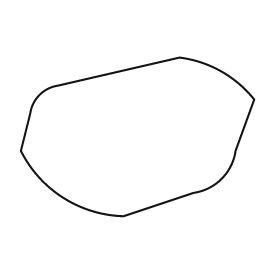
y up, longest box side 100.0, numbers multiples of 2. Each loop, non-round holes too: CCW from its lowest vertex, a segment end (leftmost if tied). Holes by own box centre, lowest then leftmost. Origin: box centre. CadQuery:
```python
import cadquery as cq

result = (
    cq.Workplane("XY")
    .moveTo(-6.0, -34.0)
    .lineTo(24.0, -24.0)
    .threePointArc((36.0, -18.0), (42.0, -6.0))
    .lineTo(50.0, 16.0)
    .threePointArc((36.0, 28.0), (18.0, 34.0))
    .lineTo(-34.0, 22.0)
    .threePointArc((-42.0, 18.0), (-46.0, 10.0))
    .lineTo(-50.0, -6.0)
    .threePointArc((-32.0, -26.0), (-6.0, -34.0))
    .close()
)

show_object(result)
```